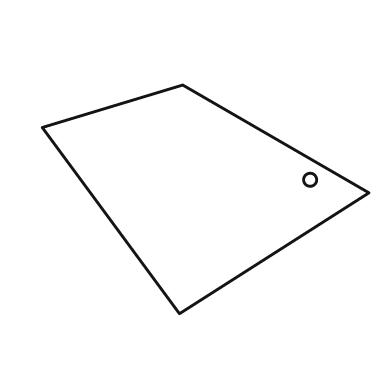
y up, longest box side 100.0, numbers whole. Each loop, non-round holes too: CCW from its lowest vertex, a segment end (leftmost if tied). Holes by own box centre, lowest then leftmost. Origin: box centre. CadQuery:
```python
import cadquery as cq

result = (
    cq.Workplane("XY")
    .moveTo(-8.0, -35.0)
    .lineTo(50.0, 2.0)
    .lineTo(-7.0, 35.0)
    .lineTo(-50.0, 22.0)
    .close()
    .moveTo(32.0, 6.0)
    .circle(2.0)
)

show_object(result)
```